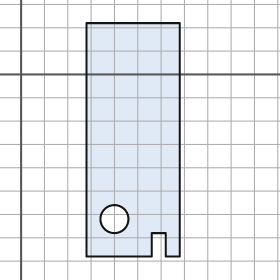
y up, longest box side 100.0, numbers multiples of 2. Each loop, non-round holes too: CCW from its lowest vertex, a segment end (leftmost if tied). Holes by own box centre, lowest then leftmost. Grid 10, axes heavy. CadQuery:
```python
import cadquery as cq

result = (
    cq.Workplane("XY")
    .moveTo(28.0, -78.0)
    .lineTo(56.0, -78.0)
    .lineTo(56.0, -68.0)
    .lineTo(62.0, -68.0)
    .lineTo(62.0, -78.0)
    .lineTo(68.0, -78.0)
    .lineTo(68.0, 22.0)
    .lineTo(28.0, 22.0)
    .close()
    .moveTo(40.0, -62.0)
    .circle(6.0)
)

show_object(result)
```